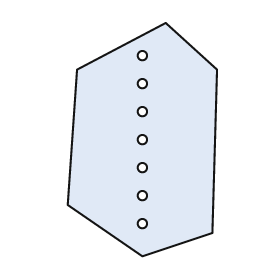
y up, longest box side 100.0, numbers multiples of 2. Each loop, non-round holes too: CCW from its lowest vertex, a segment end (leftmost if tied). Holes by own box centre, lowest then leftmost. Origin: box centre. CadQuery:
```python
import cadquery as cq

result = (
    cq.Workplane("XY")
    .moveTo(0.0, -50.0)
    .lineTo(30.0, -40.0)
    .lineTo(32.0, 30.0)
    .lineTo(10.0, 50.0)
    .lineTo(-28.0, 30.0)
    .lineTo(-32.0, -28.0)
    .close()
    .moveTo(0.0, -36.0)
    .circle(2.0)
    .moveTo(0.0, -24.0)
    .circle(2.0)
    .moveTo(0.0, -12.0)
    .circle(2.0)
    .moveTo(0.0, 0.0)
    .circle(2.0)
    .moveTo(0.0, 12.0)
    .circle(2.0)
    .moveTo(0.0, 24.0)
    .circle(2.0)
    .moveTo(0.0, 36.0)
    .circle(2.0)
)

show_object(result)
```